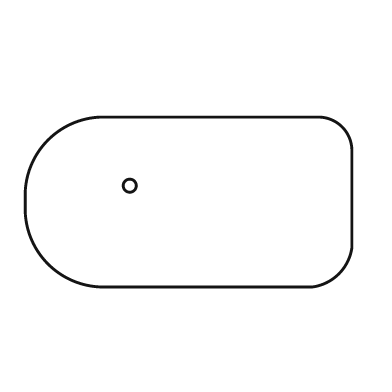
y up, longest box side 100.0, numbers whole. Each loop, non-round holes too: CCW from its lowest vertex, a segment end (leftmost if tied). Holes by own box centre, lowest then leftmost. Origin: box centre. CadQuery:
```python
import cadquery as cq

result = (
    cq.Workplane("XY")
    .moveTo(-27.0, -26.0)
    .lineTo(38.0, -26.0)
    .threePointArc((46.0, -22.0), (50.0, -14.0))
    .lineTo(50.0, 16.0)
    .threePointArc((47.0, 23.0), (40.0, 26.0))
    .lineTo(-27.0, 26.0)
    .threePointArc((-43.0, 19.0), (-50.0, 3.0))
    .lineTo(-50.0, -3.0)
    .threePointArc((-43.0, -19.0), (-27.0, -26.0))
    .close()
    .moveTo(-18.0, 5.0)
    .circle(2.0)
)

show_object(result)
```